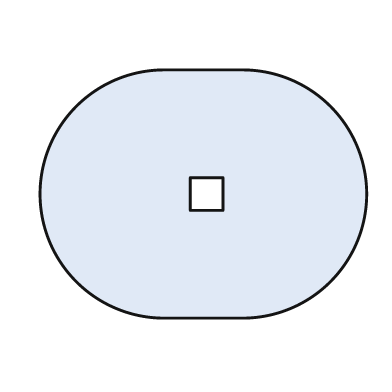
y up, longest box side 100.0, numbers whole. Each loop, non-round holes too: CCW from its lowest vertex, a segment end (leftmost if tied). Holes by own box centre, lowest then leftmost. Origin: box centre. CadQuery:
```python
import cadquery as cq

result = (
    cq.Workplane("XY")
    .moveTo(-12.0, -38.0)
    .lineTo(12.0, -38.0)
    .threePointArc((50.0, 0.0), (12.0, 38.0))
    .lineTo(-12.0, 38.0)
    .threePointArc((-50.0, 0.0), (-12.0, -38.0))
    .close()
    .moveTo(-4.0, -5.0)
    .lineTo(6.0, -5.0)
    .lineTo(6.0, 5.0)
    .lineTo(-4.0, 5.0)
    .close()
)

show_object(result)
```